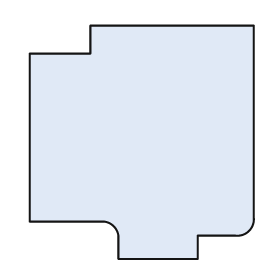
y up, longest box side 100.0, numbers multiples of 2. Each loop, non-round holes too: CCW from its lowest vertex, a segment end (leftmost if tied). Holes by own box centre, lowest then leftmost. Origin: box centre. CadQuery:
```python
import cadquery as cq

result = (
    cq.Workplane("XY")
    .moveTo(-10.0, -50.0)
    .lineTo(24.0, -50.0)
    .lineTo(24.0, -40.0)
    .lineTo(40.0, -40.0)
    .threePointArc((46.0, -38.0), (48.0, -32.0))
    .lineTo(48.0, 50.0)
    .lineTo(-22.0, 50.0)
    .lineTo(-22.0, 38.0)
    .lineTo(-48.0, 38.0)
    .lineTo(-48.0, -34.0)
    .lineTo(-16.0, -34.0)
    .threePointArc((-12.0, -36.0), (-10.0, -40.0))
    .close()
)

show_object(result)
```